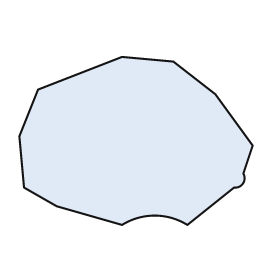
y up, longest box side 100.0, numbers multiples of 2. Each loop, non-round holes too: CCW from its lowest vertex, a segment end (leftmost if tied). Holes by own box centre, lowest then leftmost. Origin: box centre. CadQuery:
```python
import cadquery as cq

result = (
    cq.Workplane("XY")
    .moveTo(-6.0, -36.0)
    .threePointArc((8.0, -32.0), (22.0, -36.0))
    .lineTo(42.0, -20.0)
    .threePointArc((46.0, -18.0), (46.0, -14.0))
    .lineTo(50.0, -2.0)
    .lineTo(34.0, 20.0)
    .lineTo(16.0, 34.0)
    .lineTo(-6.0, 36.0)
    .lineTo(-42.0, 22.0)
    .lineTo(-50.0, 2.0)
    .lineTo(-48.0, -20.0)
    .lineTo(-34.0, -28.0)
    .close()
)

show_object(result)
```